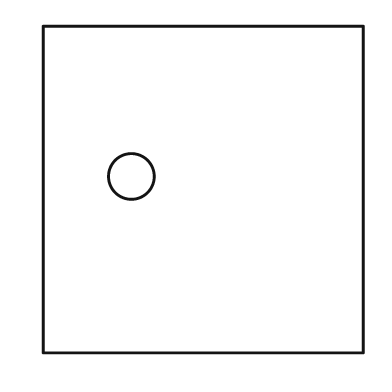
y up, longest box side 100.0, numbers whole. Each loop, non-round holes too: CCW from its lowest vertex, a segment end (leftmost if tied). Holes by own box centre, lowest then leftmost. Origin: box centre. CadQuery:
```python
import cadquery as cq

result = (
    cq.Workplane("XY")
    .moveTo(-49.0, -50.0)
    .lineTo(49.0, -50.0)
    .lineTo(49.0, 50.0)
    .lineTo(-49.0, 50.0)
    .close()
    .moveTo(-22.0, 4.0)
    .circle(7.0)
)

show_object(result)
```